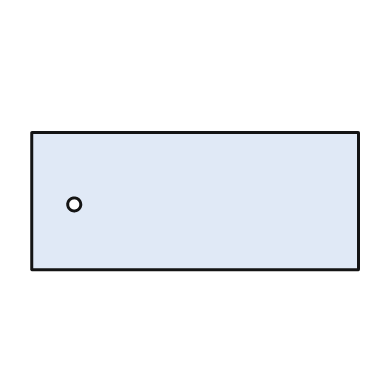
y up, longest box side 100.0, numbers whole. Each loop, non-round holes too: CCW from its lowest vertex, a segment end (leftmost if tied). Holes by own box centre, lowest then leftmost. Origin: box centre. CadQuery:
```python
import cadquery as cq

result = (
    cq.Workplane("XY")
    .moveTo(-50.0, -21.0)
    .lineTo(50.0, -21.0)
    .lineTo(50.0, 21.0)
    .lineTo(-50.0, 21.0)
    .close()
    .moveTo(-37.0, -1.0)
    .circle(2.0)
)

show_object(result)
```